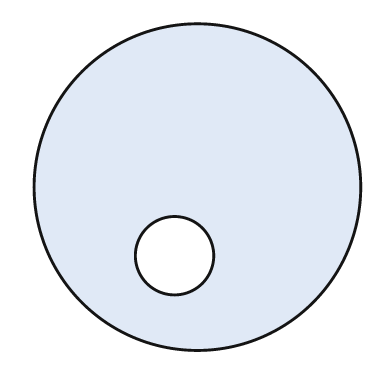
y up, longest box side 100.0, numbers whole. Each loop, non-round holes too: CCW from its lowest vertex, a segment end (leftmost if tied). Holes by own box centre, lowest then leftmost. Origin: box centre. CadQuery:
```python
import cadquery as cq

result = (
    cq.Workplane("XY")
    .moveTo(0.0, 0.0)
    .circle(50.0)
    .moveTo(-7.0, -21.0)
    .circle(12.0)
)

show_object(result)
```